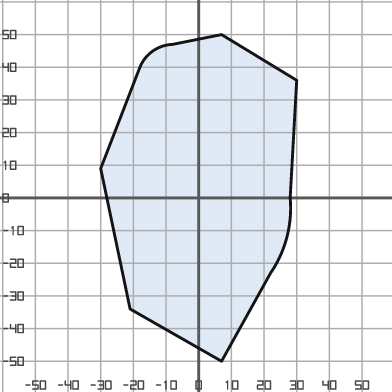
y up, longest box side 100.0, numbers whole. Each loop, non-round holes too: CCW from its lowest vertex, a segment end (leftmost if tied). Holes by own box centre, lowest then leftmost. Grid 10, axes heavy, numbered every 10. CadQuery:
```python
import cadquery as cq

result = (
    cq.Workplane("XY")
    .moveTo(7.0, -50.0)
    .lineTo(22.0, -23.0)
    .threePointArc((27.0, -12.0), (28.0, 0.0))
    .lineTo(30.0, 36.0)
    .lineTo(7.0, 50.0)
    .lineTo(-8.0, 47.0)
    .threePointArc((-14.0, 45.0), (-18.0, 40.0))
    .lineTo(-30.0, 9.0)
    .lineTo(-21.0, -34.0)
    .close()
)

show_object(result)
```